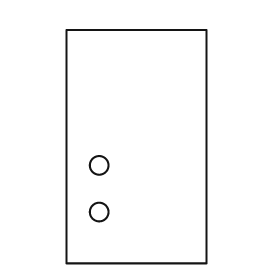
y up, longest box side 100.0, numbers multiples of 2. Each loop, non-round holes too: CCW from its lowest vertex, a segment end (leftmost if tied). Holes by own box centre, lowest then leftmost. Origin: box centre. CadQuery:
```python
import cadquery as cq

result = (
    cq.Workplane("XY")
    .moveTo(-30.0, -50.0)
    .lineTo(30.0, -50.0)
    .lineTo(30.0, 50.0)
    .lineTo(-30.0, 50.0)
    .close()
    .moveTo(-16.0, -28.0)
    .circle(4.0)
    .moveTo(-16.0, -8.0)
    .circle(4.0)
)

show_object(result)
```